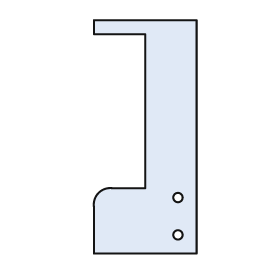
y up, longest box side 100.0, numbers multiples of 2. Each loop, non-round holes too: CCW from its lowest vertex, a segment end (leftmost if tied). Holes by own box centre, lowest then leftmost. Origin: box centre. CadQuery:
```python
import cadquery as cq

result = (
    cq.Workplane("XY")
    .moveTo(-22.0, -50.0)
    .lineTo(22.0, -50.0)
    .lineTo(22.0, 50.0)
    .lineTo(-22.0, 50.0)
    .lineTo(-22.0, 44.0)
    .lineTo(0.0, 44.0)
    .lineTo(0.0, -22.0)
    .lineTo(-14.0, -22.0)
    .threePointArc((-20.0, -24.0), (-22.0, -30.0))
    .close()
    .moveTo(14.0, -42.0)
    .circle(2.0)
    .moveTo(14.0, -26.0)
    .circle(2.0)
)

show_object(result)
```